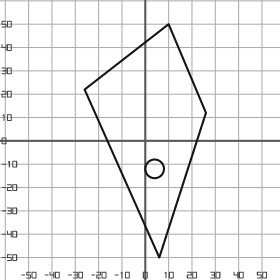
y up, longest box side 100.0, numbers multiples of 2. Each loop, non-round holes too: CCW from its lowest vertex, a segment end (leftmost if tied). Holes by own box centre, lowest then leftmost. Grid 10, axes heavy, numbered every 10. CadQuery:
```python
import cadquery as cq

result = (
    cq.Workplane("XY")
    .moveTo(6.0, -50.0)
    .lineTo(26.0, 12.0)
    .lineTo(10.0, 50.0)
    .lineTo(-26.0, 22.0)
    .close()
    .moveTo(4.0, -12.0)
    .circle(4.0)
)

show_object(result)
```